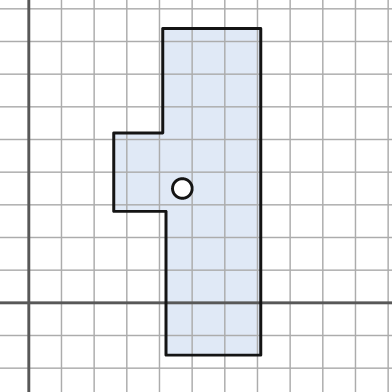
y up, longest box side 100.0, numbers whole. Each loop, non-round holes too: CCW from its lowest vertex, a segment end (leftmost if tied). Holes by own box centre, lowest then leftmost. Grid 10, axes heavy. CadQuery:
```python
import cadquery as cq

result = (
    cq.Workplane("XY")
    .moveTo(42.0, -16.0)
    .lineTo(71.0, -16.0)
    .lineTo(71.0, 84.0)
    .lineTo(41.0, 84.0)
    .lineTo(41.0, 52.0)
    .lineTo(26.0, 52.0)
    .lineTo(26.0, 28.0)
    .lineTo(42.0, 28.0)
    .close()
    .moveTo(47.0, 35.0)
    .circle(3.0)
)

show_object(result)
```